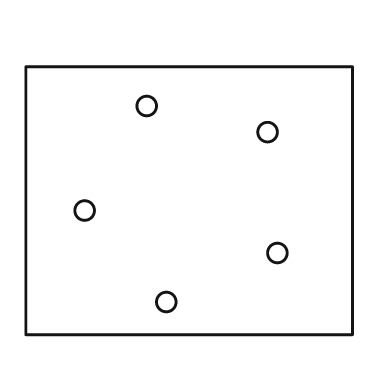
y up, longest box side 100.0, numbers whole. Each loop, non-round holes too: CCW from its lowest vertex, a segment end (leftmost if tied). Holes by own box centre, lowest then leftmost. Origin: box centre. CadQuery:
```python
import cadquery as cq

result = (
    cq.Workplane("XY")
    .moveTo(-50.0, -41.0)
    .lineTo(50.0, -41.0)
    .lineTo(50.0, 41.0)
    .lineTo(-50.0, 41.0)
    .close()
    .moveTo(-7.0, -31.0)
    .circle(3.0)
    .moveTo(27.0, -16.0)
    .circle(3.0)
    .moveTo(-32.0, -3.0)
    .circle(3.0)
    .moveTo(24.0, 21.0)
    .circle(3.0)
    .moveTo(-13.0, 29.0)
    .circle(3.0)
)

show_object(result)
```